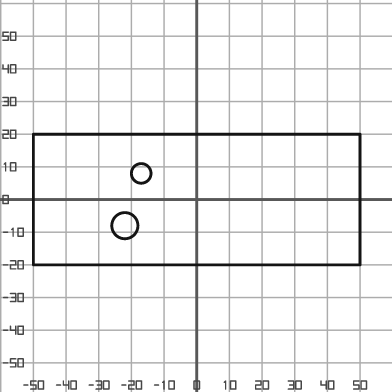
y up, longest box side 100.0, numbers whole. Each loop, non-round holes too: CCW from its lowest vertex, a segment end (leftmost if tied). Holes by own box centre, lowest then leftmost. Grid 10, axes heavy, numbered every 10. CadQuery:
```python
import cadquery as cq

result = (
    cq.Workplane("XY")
    .moveTo(-50.0, -20.0)
    .lineTo(50.0, -20.0)
    .lineTo(50.0, 20.0)
    .lineTo(-50.0, 20.0)
    .close()
    .moveTo(-22.0, -8.0)
    .circle(4.0)
    .moveTo(-17.0, 8.0)
    .circle(3.0)
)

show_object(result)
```